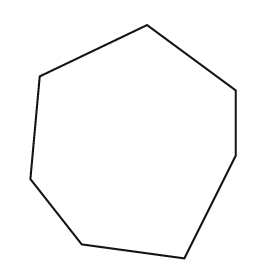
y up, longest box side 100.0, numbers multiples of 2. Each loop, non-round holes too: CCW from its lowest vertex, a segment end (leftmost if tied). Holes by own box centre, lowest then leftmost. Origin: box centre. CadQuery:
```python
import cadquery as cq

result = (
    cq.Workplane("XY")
    .moveTo(22.0, -50.0)
    .lineTo(44.0, -6.0)
    .lineTo(44.0, 22.0)
    .lineTo(6.0, 50.0)
    .lineTo(-40.0, 28.0)
    .lineTo(-44.0, -16.0)
    .lineTo(-22.0, -44.0)
    .close()
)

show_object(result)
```